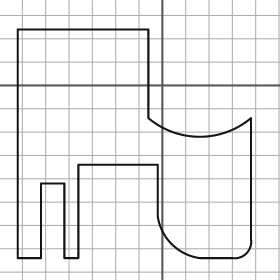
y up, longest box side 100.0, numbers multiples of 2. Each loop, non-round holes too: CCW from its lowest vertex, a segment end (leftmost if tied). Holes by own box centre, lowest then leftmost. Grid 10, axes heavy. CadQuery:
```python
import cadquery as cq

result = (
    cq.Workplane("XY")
    .moveTo(-62.0, -74.0)
    .lineTo(-52.0, -74.0)
    .lineTo(-52.0, -42.0)
    .lineTo(-42.0, -42.0)
    .lineTo(-42.0, -74.0)
    .lineTo(-36.0, -74.0)
    .lineTo(-36.0, -34.0)
    .lineTo(-2.0, -34.0)
    .lineTo(-2.0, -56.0)
    .threePointArc((4.0, -68.0), (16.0, -74.0))
    .lineTo(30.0, -74.0)
    .threePointArc((36.0, -72.0), (38.0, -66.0))
    .lineTo(38.0, -14.0)
    .threePointArc((16.0, -22.0), (-6.0, -14.0))
    .lineTo(-6.0, 24.0)
    .lineTo(-62.0, 24.0)
    .close()
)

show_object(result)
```